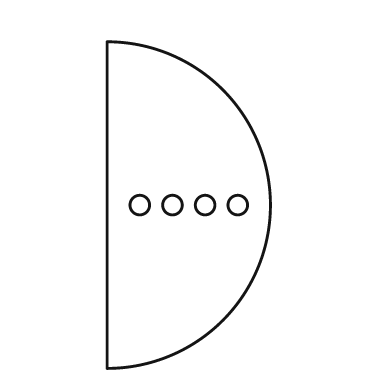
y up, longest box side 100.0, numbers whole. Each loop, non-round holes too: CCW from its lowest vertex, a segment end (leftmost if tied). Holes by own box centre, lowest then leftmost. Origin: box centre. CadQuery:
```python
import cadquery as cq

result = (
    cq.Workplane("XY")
    .moveTo(-25.0, -50.0)
    .threePointArc((25.0, 0.0), (-25.0, 50.0))
    .close()
    .moveTo(-15.0, 0.0)
    .circle(3.0)
    .moveTo(-5.0, 0.0)
    .circle(3.0)
    .moveTo(5.0, 0.0)
    .circle(3.0)
    .moveTo(15.0, 0.0)
    .circle(3.0)
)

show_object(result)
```